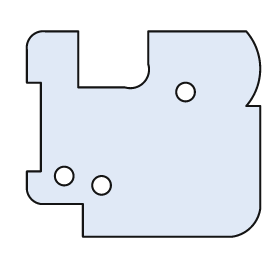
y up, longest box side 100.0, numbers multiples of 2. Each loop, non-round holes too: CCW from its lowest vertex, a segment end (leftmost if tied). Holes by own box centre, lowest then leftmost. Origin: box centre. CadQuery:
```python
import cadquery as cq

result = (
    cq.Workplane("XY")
    .moveTo(-26.0, -44.0)
    .lineTo(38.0, -44.0)
    .threePointArc((46.0, -40.0), (50.0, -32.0))
    .lineTo(50.0, 12.0)
    .lineTo(44.0, 12.0)
    .threePointArc((50.0, 28.0), (44.0, 44.0))
    .lineTo(2.0, 44.0)
    .lineTo(2.0, 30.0)
    .threePointArc((0.0, 22.0), (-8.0, 20.0))
    .lineTo(-28.0, 20.0)
    .lineTo(-28.0, 44.0)
    .lineTo(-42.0, 44.0)
    .threePointArc((-48.0, 42.0), (-50.0, 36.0))
    .lineTo(-50.0, 22.0)
    .lineTo(-44.0, 22.0)
    .lineTo(-44.0, -16.0)
    .lineTo(-50.0, -16.0)
    .lineTo(-50.0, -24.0)
    .threePointArc((-48.0, -28.0), (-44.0, -30.0))
    .lineTo(-26.0, -30.0)
    .close()
    .moveTo(-18.0, -22.0)
    .circle(4.0)
    .moveTo(-34.0, -18.0)
    .circle(4.0)
    .moveTo(18.0, 18.0)
    .circle(4.0)
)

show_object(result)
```